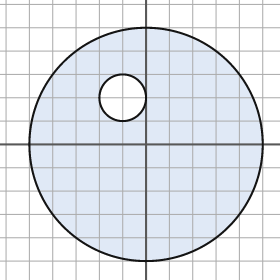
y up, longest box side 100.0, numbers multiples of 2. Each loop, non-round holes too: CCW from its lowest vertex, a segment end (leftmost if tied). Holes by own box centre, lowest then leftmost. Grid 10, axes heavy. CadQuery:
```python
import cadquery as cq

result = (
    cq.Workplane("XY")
    .moveTo(0.0, 0.0)
    .circle(50.0)
    .moveTo(-10.0, 20.0)
    .circle(10.0)
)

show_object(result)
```